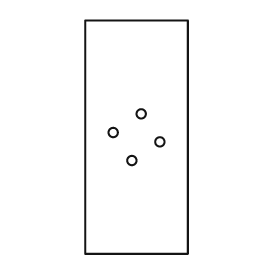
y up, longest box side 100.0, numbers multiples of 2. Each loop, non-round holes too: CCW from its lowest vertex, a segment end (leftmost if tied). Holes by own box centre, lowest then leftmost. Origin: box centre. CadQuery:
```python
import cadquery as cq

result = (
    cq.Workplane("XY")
    .moveTo(-22.0, -50.0)
    .lineTo(22.0, -50.0)
    .lineTo(22.0, 50.0)
    .lineTo(-22.0, 50.0)
    .close()
    .moveTo(-2.0, -10.0)
    .circle(2.0)
    .moveTo(10.0, -2.0)
    .circle(2.0)
    .moveTo(-10.0, 2.0)
    .circle(2.0)
    .moveTo(2.0, 10.0)
    .circle(2.0)
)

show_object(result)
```